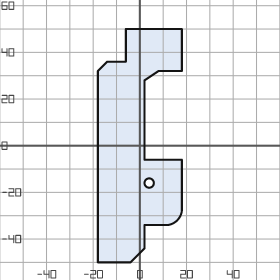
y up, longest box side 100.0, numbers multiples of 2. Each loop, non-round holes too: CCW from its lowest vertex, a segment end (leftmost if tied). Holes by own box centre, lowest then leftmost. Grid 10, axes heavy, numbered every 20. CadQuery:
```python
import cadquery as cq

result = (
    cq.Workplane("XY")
    .moveTo(-18.0, -50.0)
    .lineTo(-4.0, -50.0)
    .lineTo(2.0, -44.0)
    .lineTo(2.0, -34.0)
    .lineTo(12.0, -34.0)
    .threePointArc((16.0, -32.0), (18.0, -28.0))
    .lineTo(18.0, -6.0)
    .lineTo(2.0, -6.0)
    .lineTo(2.0, 28.0)
    .lineTo(8.0, 32.0)
    .lineTo(18.0, 32.0)
    .lineTo(18.0, 50.0)
    .lineTo(-6.0, 50.0)
    .lineTo(-6.0, 36.0)
    .lineTo(-14.0, 36.0)
    .lineTo(-18.0, 32.0)
    .close()
    .moveTo(4.0, -16.0)
    .circle(2.0)
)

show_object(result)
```